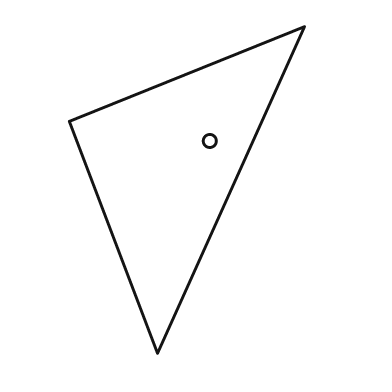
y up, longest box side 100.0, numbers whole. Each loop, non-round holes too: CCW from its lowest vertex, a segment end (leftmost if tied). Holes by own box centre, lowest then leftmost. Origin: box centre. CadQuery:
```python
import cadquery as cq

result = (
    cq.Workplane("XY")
    .moveTo(-9.0, -50.0)
    .lineTo(36.0, 50.0)
    .lineTo(-36.0, 21.0)
    .close()
    .moveTo(7.0, 15.0)
    .circle(2.0)
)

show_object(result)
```